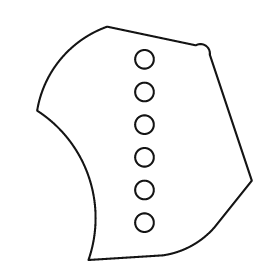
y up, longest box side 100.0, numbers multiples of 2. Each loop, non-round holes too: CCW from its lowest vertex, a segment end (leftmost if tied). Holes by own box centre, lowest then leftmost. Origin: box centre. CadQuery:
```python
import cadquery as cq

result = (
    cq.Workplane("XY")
    .moveTo(-24.0, -50.0)
    .lineTo(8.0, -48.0)
    .threePointArc((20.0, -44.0), (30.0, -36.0))
    .lineTo(46.0, -16.0)
    .lineTo(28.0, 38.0)
    .threePointArc((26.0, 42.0), (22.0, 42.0))
    .lineTo(-16.0, 50.0)
    .threePointArc((-36.0, 36.0), (-46.0, 14.0))
    .threePointArc((-24.0, -14.0), (-24.0, -50.0))
    .close()
    .moveTo(0.0, -34.0)
    .circle(4.0)
    .moveTo(0.0, -20.0)
    .circle(4.0)
    .moveTo(0.0, -6.0)
    .circle(4.0)
    .moveTo(0.0, 8.0)
    .circle(4.0)
    .moveTo(0.0, 22.0)
    .circle(4.0)
    .moveTo(0.0, 36.0)
    .circle(4.0)
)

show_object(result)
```